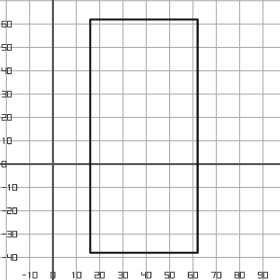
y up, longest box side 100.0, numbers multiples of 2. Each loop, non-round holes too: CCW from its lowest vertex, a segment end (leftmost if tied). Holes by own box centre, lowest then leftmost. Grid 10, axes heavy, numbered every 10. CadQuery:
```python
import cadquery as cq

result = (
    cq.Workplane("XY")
    .moveTo(16.0, -38.0)
    .lineTo(62.0, -38.0)
    .lineTo(62.0, 62.0)
    .lineTo(16.0, 62.0)
    .close()
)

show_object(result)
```